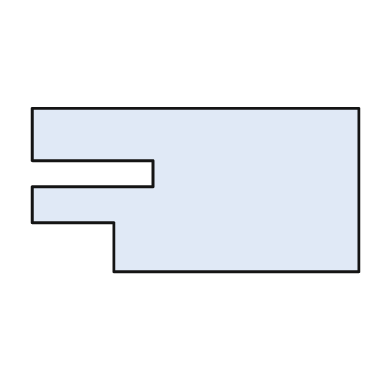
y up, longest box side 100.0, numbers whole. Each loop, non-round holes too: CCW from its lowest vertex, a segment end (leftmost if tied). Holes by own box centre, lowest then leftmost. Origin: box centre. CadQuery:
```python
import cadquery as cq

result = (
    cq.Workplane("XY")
    .moveTo(-25.0, -25.0)
    .lineTo(50.0, -25.0)
    .lineTo(50.0, 25.0)
    .lineTo(-50.0, 25.0)
    .lineTo(-50.0, 9.0)
    .lineTo(-13.0, 9.0)
    .lineTo(-13.0, 1.0)
    .lineTo(-50.0, 1.0)
    .lineTo(-50.0, -10.0)
    .lineTo(-25.0, -10.0)
    .close()
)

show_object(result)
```